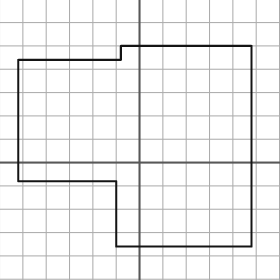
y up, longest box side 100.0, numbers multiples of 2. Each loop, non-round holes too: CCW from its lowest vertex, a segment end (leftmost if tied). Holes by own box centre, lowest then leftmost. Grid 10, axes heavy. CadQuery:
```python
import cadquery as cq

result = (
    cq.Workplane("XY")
    .moveTo(-10.0, -36.0)
    .lineTo(48.0, -36.0)
    .lineTo(48.0, 50.0)
    .lineTo(-8.0, 50.0)
    .lineTo(-8.0, 44.0)
    .lineTo(-52.0, 44.0)
    .lineTo(-52.0, -8.0)
    .lineTo(-10.0, -8.0)
    .close()
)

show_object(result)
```